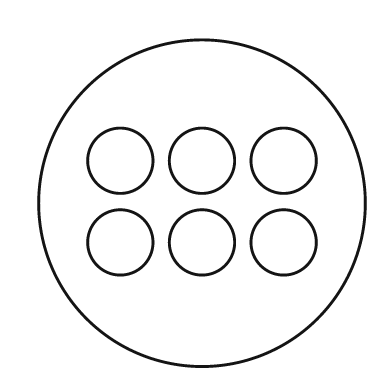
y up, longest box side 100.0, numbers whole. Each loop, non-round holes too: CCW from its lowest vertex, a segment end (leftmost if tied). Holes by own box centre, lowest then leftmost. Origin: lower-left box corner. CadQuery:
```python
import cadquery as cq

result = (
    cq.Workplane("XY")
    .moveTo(50.0, 50.0)
    .circle(50.0)
    .moveTo(25.0, 38.0)
    .circle(10.0)
    .moveTo(50.0, 38.0)
    .circle(10.0)
    .moveTo(75.0, 38.0)
    .circle(10.0)
    .moveTo(25.0, 63.0)
    .circle(10.0)
    .moveTo(50.0, 63.0)
    .circle(10.0)
    .moveTo(75.0, 63.0)
    .circle(10.0)
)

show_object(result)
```